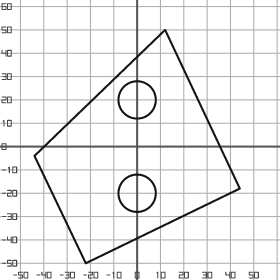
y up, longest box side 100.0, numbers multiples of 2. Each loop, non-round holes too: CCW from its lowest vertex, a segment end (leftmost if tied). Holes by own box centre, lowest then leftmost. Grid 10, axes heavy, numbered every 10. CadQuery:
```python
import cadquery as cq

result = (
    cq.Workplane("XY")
    .moveTo(-22.0, -50.0)
    .lineTo(44.0, -18.0)
    .lineTo(12.0, 50.0)
    .lineTo(-44.0, -4.0)
    .close()
    .moveTo(0.0, -20.0)
    .circle(8.0)
    .moveTo(0.0, 20.0)
    .circle(8.0)
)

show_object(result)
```